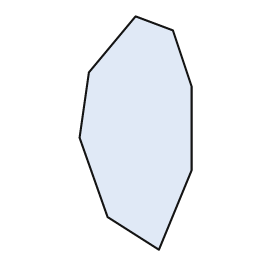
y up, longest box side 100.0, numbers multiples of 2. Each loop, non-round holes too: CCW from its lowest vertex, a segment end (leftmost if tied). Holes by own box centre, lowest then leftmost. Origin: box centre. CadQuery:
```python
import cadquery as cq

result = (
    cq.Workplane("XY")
    .moveTo(10.0, -50.0)
    .lineTo(24.0, -16.0)
    .lineTo(24.0, 20.0)
    .lineTo(16.0, 44.0)
    .lineTo(0.0, 50.0)
    .lineTo(-20.0, 26.0)
    .lineTo(-24.0, -2.0)
    .lineTo(-12.0, -36.0)
    .close()
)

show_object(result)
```